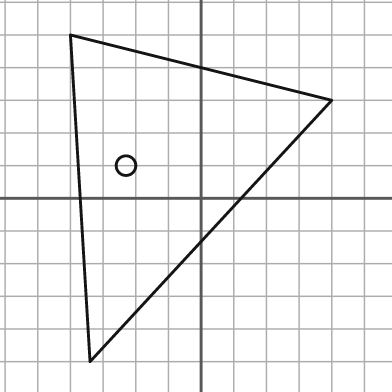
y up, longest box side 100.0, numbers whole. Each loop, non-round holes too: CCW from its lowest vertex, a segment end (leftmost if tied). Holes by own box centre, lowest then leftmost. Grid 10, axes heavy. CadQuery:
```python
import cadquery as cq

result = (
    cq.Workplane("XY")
    .moveTo(-34.0, -50.0)
    .lineTo(40.0, 30.0)
    .lineTo(-40.0, 50.0)
    .close()
    .moveTo(-23.0, 10.0)
    .circle(3.0)
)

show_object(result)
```